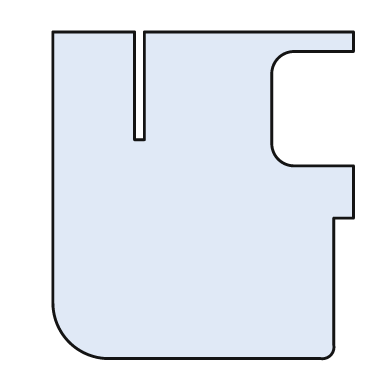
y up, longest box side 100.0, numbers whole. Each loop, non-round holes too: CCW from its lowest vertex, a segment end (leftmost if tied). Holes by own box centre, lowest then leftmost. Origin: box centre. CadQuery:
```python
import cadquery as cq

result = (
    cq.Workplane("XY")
    .moveTo(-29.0, -50.0)
    .lineTo(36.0, -50.0)
    .threePointArc((39.0, -49.0), (40.0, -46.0))
    .lineTo(40.0, -7.0)
    .lineTo(46.0, -7.0)
    .lineTo(46.0, 9.0)
    .lineTo(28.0, 9.0)
    .threePointArc((23.0, 11.0), (21.0, 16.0))
    .lineTo(21.0, 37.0)
    .threePointArc((23.0, 42.0), (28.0, 44.0))
    .lineTo(46.0, 44.0)
    .lineTo(46.0, 50.0)
    .lineTo(-18.0, 50.0)
    .lineTo(-18.0, 17.0)
    .lineTo(-21.0, 17.0)
    .lineTo(-21.0, 50.0)
    .lineTo(-46.0, 50.0)
    .lineTo(-46.0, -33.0)
    .threePointArc((-41.0, -45.0), (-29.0, -50.0))
    .close()
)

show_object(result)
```